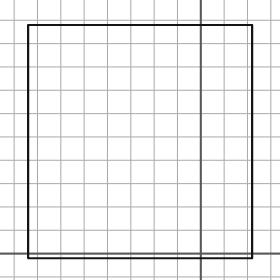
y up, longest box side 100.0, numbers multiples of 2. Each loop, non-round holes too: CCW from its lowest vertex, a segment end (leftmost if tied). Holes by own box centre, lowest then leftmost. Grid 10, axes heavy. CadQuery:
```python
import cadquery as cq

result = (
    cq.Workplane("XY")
    .moveTo(-74.0, -2.0)
    .lineTo(22.0, -2.0)
    .lineTo(22.0, 98.0)
    .lineTo(-74.0, 98.0)
    .close()
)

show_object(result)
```